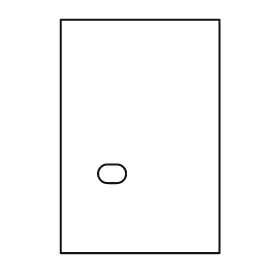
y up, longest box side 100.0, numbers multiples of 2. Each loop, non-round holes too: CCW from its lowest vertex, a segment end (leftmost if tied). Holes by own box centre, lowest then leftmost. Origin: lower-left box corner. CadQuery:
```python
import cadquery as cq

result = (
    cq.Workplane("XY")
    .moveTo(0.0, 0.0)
    .lineTo(68.0, 0.0)
    .lineTo(68.0, 100.0)
    .lineTo(0.0, 100.0)
    .close()
    .moveTo(20.0, 30.0)
    .lineTo(24.0, 30.0)
    .threePointArc((28.0, 34.0), (24.0, 38.0))
    .lineTo(20.0, 38.0)
    .threePointArc((16.0, 34.0), (20.0, 30.0))
    .close()
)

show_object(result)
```